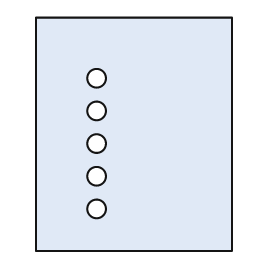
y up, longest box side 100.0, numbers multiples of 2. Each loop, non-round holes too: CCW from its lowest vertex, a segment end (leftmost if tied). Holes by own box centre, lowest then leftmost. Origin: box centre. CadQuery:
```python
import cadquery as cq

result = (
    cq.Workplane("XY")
    .moveTo(-42.0, -50.0)
    .lineTo(42.0, -50.0)
    .lineTo(42.0, 50.0)
    .lineTo(-42.0, 50.0)
    .close()
    .moveTo(-16.0, -32.0)
    .circle(4.0)
    .moveTo(-16.0, -18.0)
    .circle(4.0)
    .moveTo(-16.0, -4.0)
    .circle(4.0)
    .moveTo(-16.0, 10.0)
    .circle(4.0)
    .moveTo(-16.0, 24.0)
    .circle(4.0)
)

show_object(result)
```